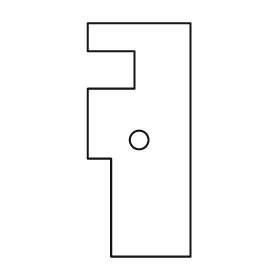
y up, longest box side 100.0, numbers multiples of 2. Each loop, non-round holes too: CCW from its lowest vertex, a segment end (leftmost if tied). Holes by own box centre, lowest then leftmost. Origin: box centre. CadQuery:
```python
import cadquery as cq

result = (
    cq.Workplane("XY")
    .moveTo(-12.0, -50.0)
    .lineTo(22.0, -50.0)
    .lineTo(22.0, 50.0)
    .lineTo(-22.0, 50.0)
    .lineTo(-22.0, 38.0)
    .lineTo(-2.0, 38.0)
    .lineTo(-2.0, 22.0)
    .lineTo(-22.0, 22.0)
    .lineTo(-22.0, -8.0)
    .lineTo(-12.0, -8.0)
    .close()
    .moveTo(0.0, 0.0)
    .circle(4.0)
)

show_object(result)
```